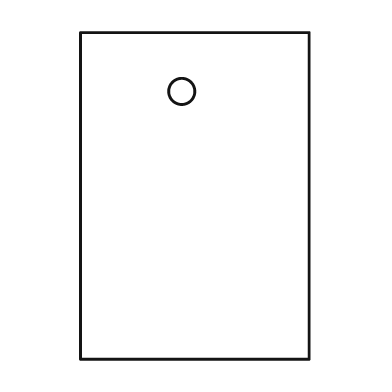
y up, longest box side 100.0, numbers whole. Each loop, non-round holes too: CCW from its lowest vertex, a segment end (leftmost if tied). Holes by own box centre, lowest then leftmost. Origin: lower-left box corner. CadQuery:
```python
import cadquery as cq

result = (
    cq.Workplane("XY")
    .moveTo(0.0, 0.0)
    .lineTo(70.0, 0.0)
    .lineTo(70.0, 100.0)
    .lineTo(0.0, 100.0)
    .close()
    .moveTo(31.0, 82.0)
    .circle(4.0)
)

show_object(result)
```